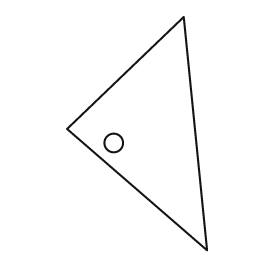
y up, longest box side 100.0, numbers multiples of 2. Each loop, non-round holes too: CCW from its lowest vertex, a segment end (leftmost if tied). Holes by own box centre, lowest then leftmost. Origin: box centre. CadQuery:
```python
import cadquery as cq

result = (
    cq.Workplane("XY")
    .moveTo(30.0, -50.0)
    .lineTo(20.0, 50.0)
    .lineTo(-30.0, 2.0)
    .close()
    .moveTo(-10.0, -4.0)
    .circle(4.0)
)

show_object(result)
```